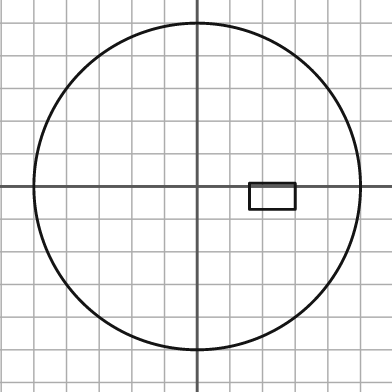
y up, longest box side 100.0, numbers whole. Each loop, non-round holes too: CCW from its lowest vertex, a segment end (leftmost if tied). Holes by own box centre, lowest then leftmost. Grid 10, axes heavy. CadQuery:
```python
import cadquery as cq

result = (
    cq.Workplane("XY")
    .moveTo(0.0, 0.0)
    .circle(50.0)
    .moveTo(16.0, -7.0)
    .lineTo(30.0, -7.0)
    .lineTo(30.0, 1.0)
    .lineTo(16.0, 1.0)
    .close()
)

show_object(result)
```